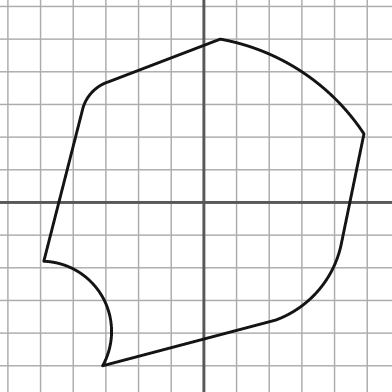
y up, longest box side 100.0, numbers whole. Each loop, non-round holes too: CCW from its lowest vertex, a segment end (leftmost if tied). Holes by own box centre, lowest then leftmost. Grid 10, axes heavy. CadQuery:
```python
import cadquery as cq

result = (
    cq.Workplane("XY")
    .moveTo(-31.0, -50.0)
    .lineTo(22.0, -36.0)
    .threePointArc((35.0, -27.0), (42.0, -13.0))
    .lineTo(49.0, 21.0)
    .threePointArc((30.0, 40.0), (5.0, 50.0))
    .lineTo(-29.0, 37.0)
    .threePointArc((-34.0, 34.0), (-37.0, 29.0))
    .lineTo(-49.0, -18.0)
    .threePointArc((-31.0, -29.0), (-31.0, -50.0))
    .close()
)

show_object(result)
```